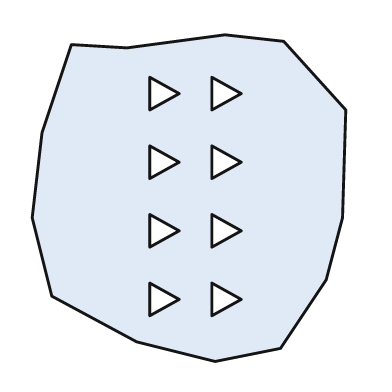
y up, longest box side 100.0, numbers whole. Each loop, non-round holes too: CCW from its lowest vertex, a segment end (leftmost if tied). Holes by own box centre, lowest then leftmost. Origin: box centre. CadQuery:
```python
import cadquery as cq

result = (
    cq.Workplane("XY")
    .moveTo(8.0, -50.0)
    .lineTo(28.0, -46.0)
    .lineTo(42.0, -25.0)
    .lineTo(47.0, -6.0)
    .lineTo(48.0, 27.0)
    .lineTo(29.0, 48.0)
    .lineTo(11.0, 50.0)
    .lineTo(-19.0, 46.0)
    .lineTo(-36.0, 47.0)
    .lineTo(-45.0, 20.0)
    .lineTo(-48.0, -6.0)
    .lineTo(-42.0, -30.0)
    .lineTo(-16.0, -44.0)
    .close()
    .moveTo(-12.0, -36.0)
    .lineTo(-3.0, -31.0)
    .lineTo(-12.0, -26.0)
    .close()
    .moveTo(7.0, -36.0)
    .lineTo(16.0, -31.0)
    .lineTo(7.0, -26.0)
    .close()
    .moveTo(-12.0, -15.0)
    .lineTo(-3.0, -10.0)
    .lineTo(-12.0, -5.0)
    .close()
    .moveTo(7.0, -15.0)
    .lineTo(16.0, -10.0)
    .lineTo(7.0, -5.0)
    .close()
    .moveTo(-12.0, 6.0)
    .lineTo(-3.0, 11.0)
    .lineTo(-12.0, 16.0)
    .close()
    .moveTo(7.0, 6.0)
    .lineTo(16.0, 11.0)
    .lineTo(7.0, 16.0)
    .close()
    .moveTo(-12.0, 27.0)
    .lineTo(-3.0, 32.0)
    .lineTo(-12.0, 37.0)
    .close()
    .moveTo(7.0, 27.0)
    .lineTo(16.0, 32.0)
    .lineTo(7.0, 37.0)
    .close()
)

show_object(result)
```